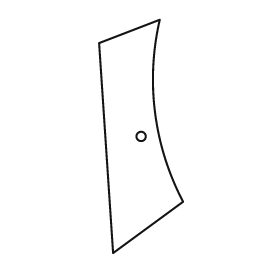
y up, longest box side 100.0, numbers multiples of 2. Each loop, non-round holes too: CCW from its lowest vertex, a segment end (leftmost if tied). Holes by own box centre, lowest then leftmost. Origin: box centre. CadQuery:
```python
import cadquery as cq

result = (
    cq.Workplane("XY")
    .moveTo(-12.0, -50.0)
    .lineTo(18.0, -28.0)
    .threePointArc((6.0, 10.0), (8.0, 50.0))
    .lineTo(-18.0, 40.0)
    .close()
    .moveTo(0.0, 0.0)
    .circle(2.0)
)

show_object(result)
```